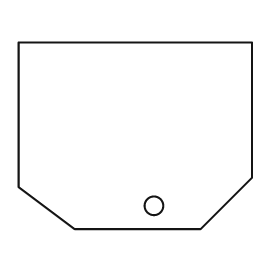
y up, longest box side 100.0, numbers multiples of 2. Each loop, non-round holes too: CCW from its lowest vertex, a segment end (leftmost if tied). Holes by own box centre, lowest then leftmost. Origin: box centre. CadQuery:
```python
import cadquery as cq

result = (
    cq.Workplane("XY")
    .moveTo(-26.0, -40.0)
    .lineTo(28.0, -40.0)
    .lineTo(50.0, -18.0)
    .lineTo(50.0, 40.0)
    .lineTo(-50.0, 40.0)
    .lineTo(-50.0, -22.0)
    .close()
    .moveTo(8.0, -30.0)
    .circle(4.0)
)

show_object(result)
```